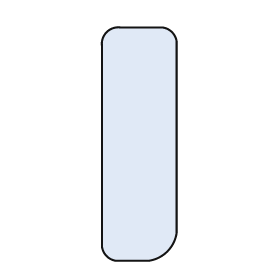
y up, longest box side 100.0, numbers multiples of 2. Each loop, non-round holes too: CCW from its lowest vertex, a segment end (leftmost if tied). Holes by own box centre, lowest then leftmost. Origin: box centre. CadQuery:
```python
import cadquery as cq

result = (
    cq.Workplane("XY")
    .moveTo(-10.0, -50.0)
    .lineTo(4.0, -50.0)
    .threePointArc((12.0, -46.0), (16.0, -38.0))
    .lineTo(16.0, 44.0)
    .threePointArc((14.0, 48.0), (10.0, 50.0))
    .lineTo(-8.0, 50.0)
    .threePointArc((-14.0, 48.0), (-16.0, 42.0))
    .lineTo(-16.0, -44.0)
    .threePointArc((-14.0, -48.0), (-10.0, -50.0))
    .close()
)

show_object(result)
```